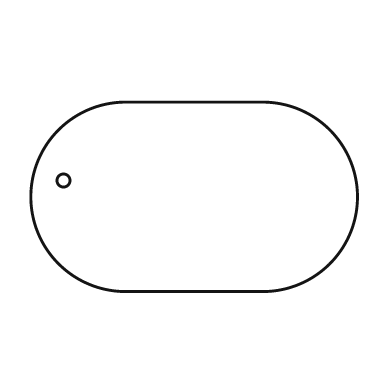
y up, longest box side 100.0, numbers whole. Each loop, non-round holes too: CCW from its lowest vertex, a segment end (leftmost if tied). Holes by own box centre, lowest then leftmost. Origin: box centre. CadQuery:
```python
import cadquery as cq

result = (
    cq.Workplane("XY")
    .moveTo(-21.0, -29.0)
    .lineTo(21.0, -29.0)
    .threePointArc((50.0, 0.0), (21.0, 29.0))
    .lineTo(-21.0, 29.0)
    .threePointArc((-50.0, 0.0), (-21.0, -29.0))
    .close()
    .moveTo(-40.0, 5.0)
    .circle(2.0)
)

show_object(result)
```